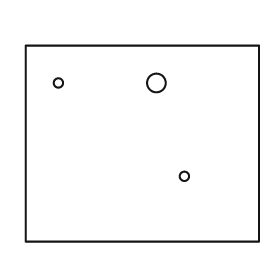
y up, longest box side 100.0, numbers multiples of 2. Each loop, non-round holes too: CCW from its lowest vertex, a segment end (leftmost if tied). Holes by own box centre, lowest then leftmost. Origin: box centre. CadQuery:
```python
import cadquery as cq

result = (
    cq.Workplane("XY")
    .moveTo(-50.0, -42.0)
    .lineTo(50.0, -42.0)
    .lineTo(50.0, 42.0)
    .lineTo(-50.0, 42.0)
    .close()
    .moveTo(18.0, -14.0)
    .circle(2.0)
    .moveTo(-36.0, 26.0)
    .circle(2.0)
    .moveTo(6.0, 26.0)
    .circle(4.0)
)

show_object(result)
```